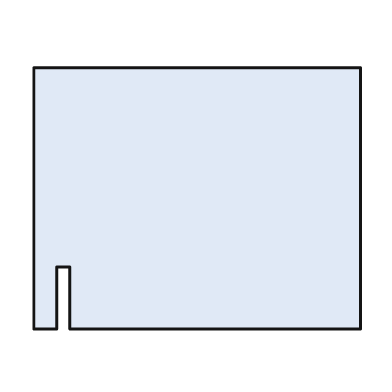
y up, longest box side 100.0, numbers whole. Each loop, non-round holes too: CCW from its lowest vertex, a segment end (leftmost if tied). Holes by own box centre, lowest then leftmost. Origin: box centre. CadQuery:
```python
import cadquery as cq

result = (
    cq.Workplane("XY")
    .moveTo(-50.0, -40.0)
    .lineTo(-43.0, -40.0)
    .lineTo(-43.0, -21.0)
    .lineTo(-39.0, -21.0)
    .lineTo(-39.0, -40.0)
    .lineTo(50.0, -40.0)
    .lineTo(50.0, 40.0)
    .lineTo(-50.0, 40.0)
    .close()
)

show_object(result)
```